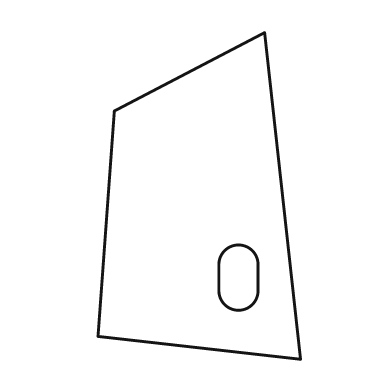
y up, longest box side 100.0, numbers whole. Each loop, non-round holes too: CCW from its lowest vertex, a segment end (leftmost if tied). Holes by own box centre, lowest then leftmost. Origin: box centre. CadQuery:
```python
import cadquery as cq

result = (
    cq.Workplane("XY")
    .moveTo(31.0, -50.0)
    .lineTo(20.0, 50.0)
    .lineTo(-26.0, 26.0)
    .lineTo(-31.0, -43.0)
    .close()
    .moveTo(6.0, -29.0)
    .threePointArc((12.0, -35.0), (18.0, -29.0))
    .lineTo(18.0, -21.0)
    .threePointArc((12.0, -15.0), (6.0, -21.0))
    .close()
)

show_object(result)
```